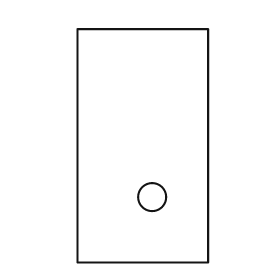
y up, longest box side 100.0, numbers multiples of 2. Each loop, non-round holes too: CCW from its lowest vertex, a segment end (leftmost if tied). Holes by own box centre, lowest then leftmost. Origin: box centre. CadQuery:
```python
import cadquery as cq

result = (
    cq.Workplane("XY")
    .moveTo(-28.0, -50.0)
    .lineTo(28.0, -50.0)
    .lineTo(28.0, 50.0)
    .lineTo(-28.0, 50.0)
    .close()
    .moveTo(4.0, -22.0)
    .circle(6.0)
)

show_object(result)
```